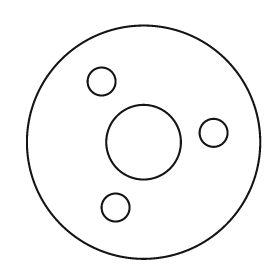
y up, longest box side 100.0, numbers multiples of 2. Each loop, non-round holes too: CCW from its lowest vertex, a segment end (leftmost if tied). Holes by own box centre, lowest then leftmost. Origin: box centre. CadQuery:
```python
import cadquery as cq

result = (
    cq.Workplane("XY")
    .moveTo(0.0, 0.0)
    .circle(50.0)
    .moveTo(-12.0, -28.0)
    .circle(6.0)
    .moveTo(0.0, 0.0)
    .circle(16.0)
    .moveTo(30.0, 4.0)
    .circle(6.0)
    .moveTo(-18.0, 26.0)
    .circle(6.0)
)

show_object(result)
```